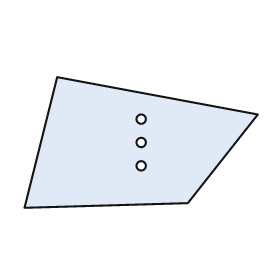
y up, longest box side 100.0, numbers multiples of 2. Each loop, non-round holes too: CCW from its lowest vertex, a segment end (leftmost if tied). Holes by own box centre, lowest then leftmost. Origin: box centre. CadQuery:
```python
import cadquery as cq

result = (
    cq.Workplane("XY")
    .moveTo(-50.0, -28.0)
    .lineTo(20.0, -26.0)
    .lineTo(50.0, 12.0)
    .lineTo(-36.0, 28.0)
    .close()
    .moveTo(0.0, -10.0)
    .circle(2.0)
    .moveTo(0.0, 0.0)
    .circle(2.0)
    .moveTo(0.0, 10.0)
    .circle(2.0)
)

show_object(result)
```